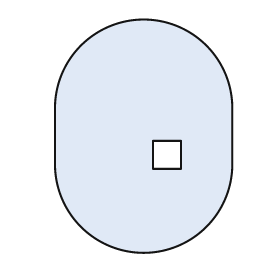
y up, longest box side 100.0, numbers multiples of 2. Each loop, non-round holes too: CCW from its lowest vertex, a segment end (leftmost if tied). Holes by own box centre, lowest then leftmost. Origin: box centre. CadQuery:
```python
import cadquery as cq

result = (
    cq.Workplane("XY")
    .moveTo(-38.0, -12.0)
    .threePointArc((0.0, -50.0), (38.0, -12.0))
    .lineTo(38.0, 12.0)
    .threePointArc((0.0, 50.0), (-38.0, 12.0))
    .close()
    .moveTo(4.0, -14.0)
    .lineTo(16.0, -14.0)
    .lineTo(16.0, -2.0)
    .lineTo(4.0, -2.0)
    .close()
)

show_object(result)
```